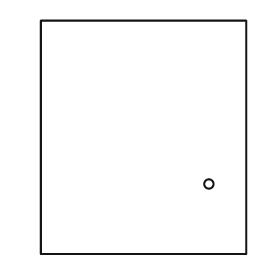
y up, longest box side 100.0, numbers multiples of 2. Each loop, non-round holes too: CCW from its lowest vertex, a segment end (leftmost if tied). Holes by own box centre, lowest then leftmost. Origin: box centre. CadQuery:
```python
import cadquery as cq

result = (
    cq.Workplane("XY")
    .moveTo(-44.0, -50.0)
    .lineTo(44.0, -50.0)
    .lineTo(44.0, 50.0)
    .lineTo(-44.0, 50.0)
    .close()
    .moveTo(28.0, -20.0)
    .circle(2.0)
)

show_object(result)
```